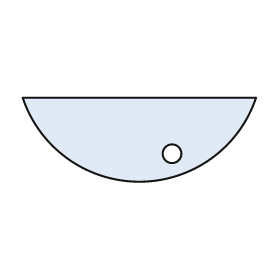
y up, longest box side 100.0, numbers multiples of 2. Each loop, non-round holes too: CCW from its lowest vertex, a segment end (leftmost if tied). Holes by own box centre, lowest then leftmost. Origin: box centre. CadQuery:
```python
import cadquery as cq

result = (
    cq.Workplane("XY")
    .moveTo(-50.0, 18.0)
    .threePointArc((0.0, -18.0), (50.0, 18.0))
    .close()
    .moveTo(14.0, -6.0)
    .circle(4.0)
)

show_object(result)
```